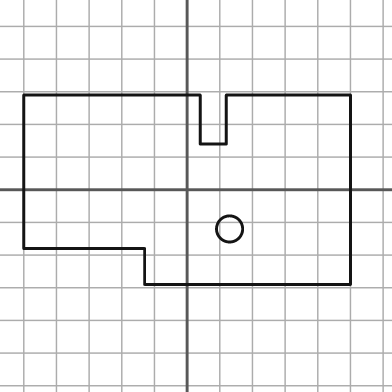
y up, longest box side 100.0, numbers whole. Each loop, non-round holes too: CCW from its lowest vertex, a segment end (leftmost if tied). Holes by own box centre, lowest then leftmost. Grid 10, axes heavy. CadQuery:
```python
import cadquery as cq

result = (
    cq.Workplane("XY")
    .moveTo(-13.0, -29.0)
    .lineTo(50.0, -29.0)
    .lineTo(50.0, 29.0)
    .lineTo(12.0, 29.0)
    .lineTo(12.0, 14.0)
    .lineTo(4.0, 14.0)
    .lineTo(4.0, 29.0)
    .lineTo(-50.0, 29.0)
    .lineTo(-50.0, -18.0)
    .lineTo(-13.0, -18.0)
    .close()
    .moveTo(13.0, -12.0)
    .circle(4.0)
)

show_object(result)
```